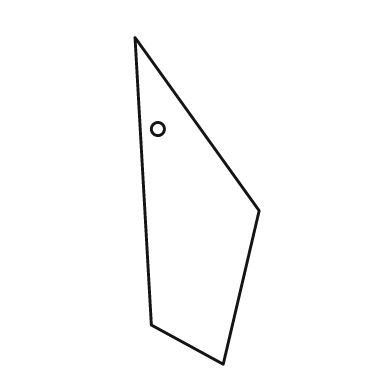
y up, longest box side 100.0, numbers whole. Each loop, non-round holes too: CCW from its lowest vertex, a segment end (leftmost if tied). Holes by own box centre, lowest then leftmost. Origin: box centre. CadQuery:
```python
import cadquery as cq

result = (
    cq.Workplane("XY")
    .moveTo(8.0, -50.0)
    .lineTo(19.0, -3.0)
    .lineTo(-19.0, 50.0)
    .lineTo(-14.0, -38.0)
    .close()
    .moveTo(-12.0, 22.0)
    .circle(2.0)
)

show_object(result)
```